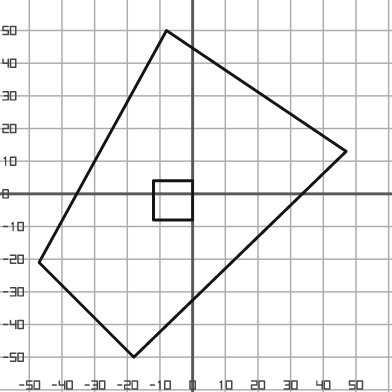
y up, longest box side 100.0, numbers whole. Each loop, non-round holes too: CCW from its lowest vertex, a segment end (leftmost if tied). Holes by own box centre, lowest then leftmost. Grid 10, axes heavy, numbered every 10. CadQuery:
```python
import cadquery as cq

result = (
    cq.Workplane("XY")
    .moveTo(-18.0, -50.0)
    .lineTo(47.0, 13.0)
    .lineTo(-8.0, 50.0)
    .lineTo(-47.0, -21.0)
    .close()
    .moveTo(-12.0, -8.0)
    .lineTo(0.0, -8.0)
    .lineTo(0.0, 4.0)
    .lineTo(-12.0, 4.0)
    .close()
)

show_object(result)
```